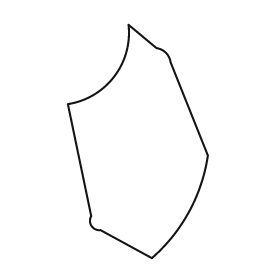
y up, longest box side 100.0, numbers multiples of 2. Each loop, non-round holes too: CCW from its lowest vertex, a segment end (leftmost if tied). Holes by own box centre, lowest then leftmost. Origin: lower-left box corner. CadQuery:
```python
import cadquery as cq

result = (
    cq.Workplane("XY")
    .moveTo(36.0, 0.0)
    .threePointArc((52.0, 20.0), (60.0, 44.0))
    .lineTo(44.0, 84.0)
    .threePointArc((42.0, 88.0), (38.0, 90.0))
    .lineTo(26.0, 100.0)
    .threePointArc((20.0, 78.0), (0.0, 66.0))
    .lineTo(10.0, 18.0)
    .threePointArc((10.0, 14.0), (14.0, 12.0))
    .close()
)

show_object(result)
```